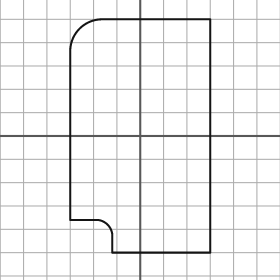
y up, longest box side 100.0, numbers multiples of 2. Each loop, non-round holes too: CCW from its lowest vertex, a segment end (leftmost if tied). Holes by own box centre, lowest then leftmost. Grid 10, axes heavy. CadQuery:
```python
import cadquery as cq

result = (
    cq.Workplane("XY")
    .moveTo(-12.0, -50.0)
    .lineTo(30.0, -50.0)
    .lineTo(30.0, 50.0)
    .lineTo(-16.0, 50.0)
    .threePointArc((-26.0, 46.0), (-30.0, 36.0))
    .lineTo(-30.0, -36.0)
    .lineTo(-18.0, -36.0)
    .threePointArc((-14.0, -38.0), (-12.0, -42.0))
    .close()
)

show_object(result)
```